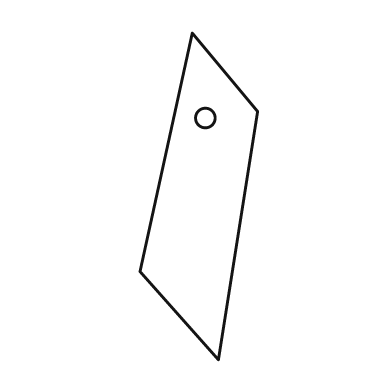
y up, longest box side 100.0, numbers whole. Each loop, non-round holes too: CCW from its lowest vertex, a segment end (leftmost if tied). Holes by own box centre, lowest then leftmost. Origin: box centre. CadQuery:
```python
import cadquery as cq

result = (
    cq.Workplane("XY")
    .moveTo(6.0, -50.0)
    .lineTo(18.0, 26.0)
    .lineTo(-2.0, 50.0)
    .lineTo(-18.0, -23.0)
    .close()
    .moveTo(2.0, 24.0)
    .circle(3.0)
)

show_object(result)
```